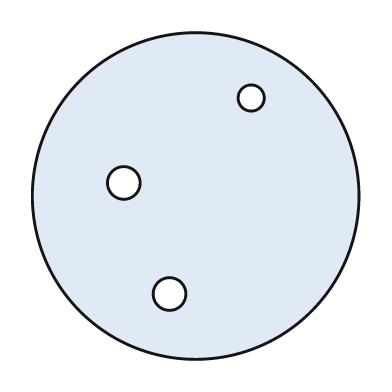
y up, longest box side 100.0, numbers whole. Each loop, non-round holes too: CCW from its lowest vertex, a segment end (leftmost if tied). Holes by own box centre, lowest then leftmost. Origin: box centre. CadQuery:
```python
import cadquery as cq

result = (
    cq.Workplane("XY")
    .moveTo(0.0, 0.0)
    .circle(50.0)
    .moveTo(-8.0, -30.0)
    .circle(5.0)
    .moveTo(-22.0, 4.0)
    .circle(5.0)
    .moveTo(17.0, 30.0)
    .circle(4.0)
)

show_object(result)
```